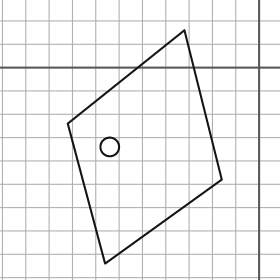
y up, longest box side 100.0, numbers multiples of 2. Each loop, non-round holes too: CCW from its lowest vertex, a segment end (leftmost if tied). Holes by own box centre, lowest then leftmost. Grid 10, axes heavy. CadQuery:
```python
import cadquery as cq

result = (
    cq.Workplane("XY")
    .moveTo(-66.0, -84.0)
    .lineTo(-16.0, -48.0)
    .lineTo(-32.0, 16.0)
    .lineTo(-82.0, -24.0)
    .close()
    .moveTo(-64.0, -34.0)
    .circle(4.0)
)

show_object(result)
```